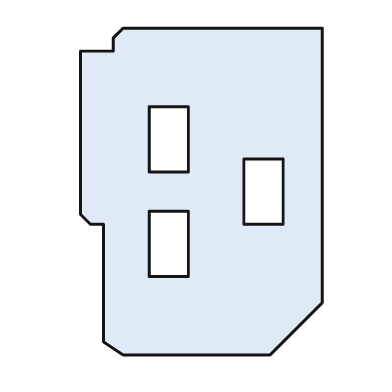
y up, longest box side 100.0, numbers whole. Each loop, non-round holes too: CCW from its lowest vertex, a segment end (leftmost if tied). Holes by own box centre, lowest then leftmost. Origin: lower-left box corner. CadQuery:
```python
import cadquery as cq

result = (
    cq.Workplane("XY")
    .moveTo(13.0, 0.0)
    .lineTo(58.0, 0.0)
    .lineTo(74.0, 16.0)
    .lineTo(74.0, 100.0)
    .lineTo(13.0, 100.0)
    .lineTo(10.0, 97.0)
    .lineTo(10.0, 93.0)
    .lineTo(0.0, 93.0)
    .lineTo(0.0, 43.0)
    .lineTo(3.0, 40.0)
    .lineTo(7.0, 40.0)
    .lineTo(7.0, 4.0)
    .close()
    .moveTo(21.0, 24.0)
    .lineTo(33.0, 24.0)
    .lineTo(33.0, 44.0)
    .lineTo(21.0, 44.0)
    .close()
    .moveTo(50.0, 40.0)
    .lineTo(62.0, 40.0)
    .lineTo(62.0, 60.0)
    .lineTo(50.0, 60.0)
    .close()
    .moveTo(21.0, 56.0)
    .lineTo(33.0, 56.0)
    .lineTo(33.0, 76.0)
    .lineTo(21.0, 76.0)
    .close()
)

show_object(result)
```